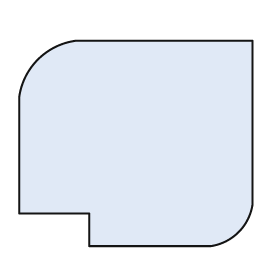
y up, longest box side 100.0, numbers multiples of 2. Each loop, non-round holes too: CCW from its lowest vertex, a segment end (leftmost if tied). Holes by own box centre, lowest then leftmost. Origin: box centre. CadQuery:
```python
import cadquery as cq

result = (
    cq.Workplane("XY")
    .moveTo(-20.0, -44.0)
    .lineTo(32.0, -44.0)
    .threePointArc((44.0, -38.0), (50.0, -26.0))
    .lineTo(50.0, 44.0)
    .lineTo(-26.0, 44.0)
    .threePointArc((-42.0, 36.0), (-50.0, 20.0))
    .lineTo(-50.0, -30.0)
    .lineTo(-20.0, -30.0)
    .close()
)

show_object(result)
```